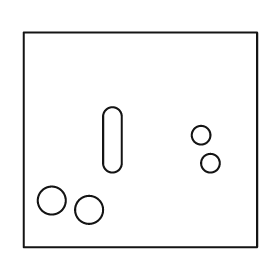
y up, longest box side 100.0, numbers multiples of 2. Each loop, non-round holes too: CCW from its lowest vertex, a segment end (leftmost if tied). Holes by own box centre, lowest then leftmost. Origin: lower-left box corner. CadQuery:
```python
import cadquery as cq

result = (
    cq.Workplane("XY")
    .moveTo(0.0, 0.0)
    .lineTo(100.0, 0.0)
    .lineTo(100.0, 92.0)
    .lineTo(0.0, 92.0)
    .close()
    .moveTo(28.0, 16.0)
    .circle(6.0)
    .moveTo(12.0, 20.0)
    .circle(6.0)
    .moveTo(80.0, 36.0)
    .circle(4.0)
    .moveTo(34.0, 36.0)
    .threePointArc((38.0, 32.0), (42.0, 36.0))
    .lineTo(42.0, 56.0)
    .threePointArc((38.0, 60.0), (34.0, 56.0))
    .close()
    .moveTo(76.0, 48.0)
    .circle(4.0)
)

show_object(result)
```